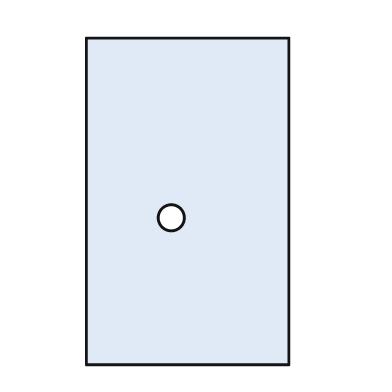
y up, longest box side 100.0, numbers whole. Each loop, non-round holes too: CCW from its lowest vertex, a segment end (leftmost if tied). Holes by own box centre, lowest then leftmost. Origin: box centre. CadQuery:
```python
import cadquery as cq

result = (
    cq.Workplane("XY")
    .moveTo(-31.0, -50.0)
    .lineTo(31.0, -50.0)
    .lineTo(31.0, 50.0)
    .lineTo(-31.0, 50.0)
    .close()
    .moveTo(-5.0, -5.0)
    .circle(4.0)
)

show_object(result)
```